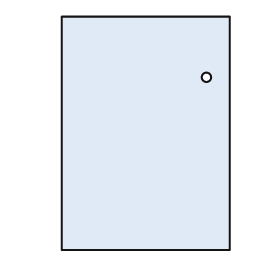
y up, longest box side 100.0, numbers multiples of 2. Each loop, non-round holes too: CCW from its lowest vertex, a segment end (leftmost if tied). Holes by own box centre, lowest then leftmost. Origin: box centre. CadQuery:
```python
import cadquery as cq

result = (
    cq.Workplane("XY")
    .moveTo(-36.0, -50.0)
    .lineTo(36.0, -50.0)
    .lineTo(36.0, 50.0)
    .lineTo(-36.0, 50.0)
    .close()
    .moveTo(26.0, 24.0)
    .circle(2.0)
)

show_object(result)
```